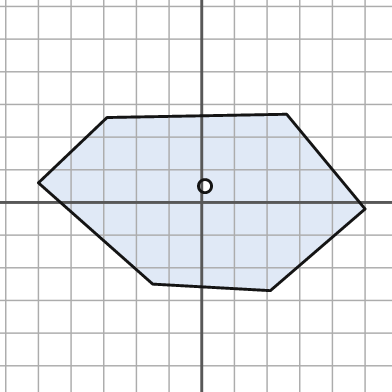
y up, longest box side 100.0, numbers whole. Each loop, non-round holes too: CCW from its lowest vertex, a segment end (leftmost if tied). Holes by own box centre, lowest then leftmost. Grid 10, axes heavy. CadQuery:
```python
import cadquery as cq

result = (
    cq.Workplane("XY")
    .moveTo(21.0, -27.0)
    .lineTo(50.0, -2.0)
    .lineTo(26.0, 27.0)
    .lineTo(-29.0, 26.0)
    .lineTo(-50.0, 6.0)
    .lineTo(-15.0, -25.0)
    .close()
    .moveTo(1.0, 5.0)
    .circle(2.0)
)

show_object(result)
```